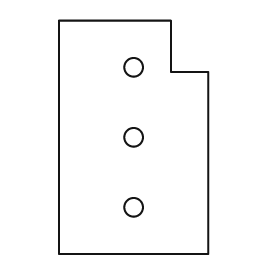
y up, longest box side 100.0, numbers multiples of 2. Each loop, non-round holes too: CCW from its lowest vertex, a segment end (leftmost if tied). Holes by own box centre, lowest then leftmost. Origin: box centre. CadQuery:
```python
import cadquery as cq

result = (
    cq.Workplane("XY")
    .moveTo(-32.0, -50.0)
    .lineTo(32.0, -50.0)
    .lineTo(32.0, 28.0)
    .lineTo(16.0, 28.0)
    .lineTo(16.0, 50.0)
    .lineTo(-32.0, 50.0)
    .close()
    .moveTo(0.0, -30.0)
    .circle(4.0)
    .moveTo(0.0, 0.0)
    .circle(4.0)
    .moveTo(0.0, 30.0)
    .circle(4.0)
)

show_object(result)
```